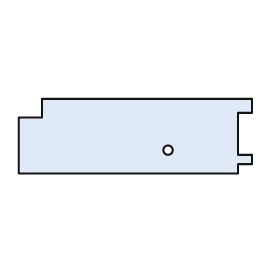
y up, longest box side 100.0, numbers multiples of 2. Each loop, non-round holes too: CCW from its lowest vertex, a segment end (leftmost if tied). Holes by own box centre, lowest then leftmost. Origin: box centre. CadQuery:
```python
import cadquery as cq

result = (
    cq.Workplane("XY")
    .moveTo(-50.0, -16.0)
    .lineTo(44.0, -16.0)
    .lineTo(44.0, -12.0)
    .lineTo(50.0, -12.0)
    .lineTo(50.0, -8.0)
    .lineTo(44.0, -8.0)
    .lineTo(44.0, 10.0)
    .lineTo(50.0, 10.0)
    .lineTo(50.0, 16.0)
    .lineTo(-40.0, 16.0)
    .lineTo(-40.0, 8.0)
    .lineTo(-50.0, 8.0)
    .close()
    .moveTo(14.0, -6.0)
    .circle(2.0)
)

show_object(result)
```